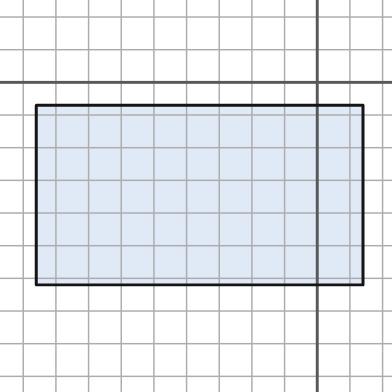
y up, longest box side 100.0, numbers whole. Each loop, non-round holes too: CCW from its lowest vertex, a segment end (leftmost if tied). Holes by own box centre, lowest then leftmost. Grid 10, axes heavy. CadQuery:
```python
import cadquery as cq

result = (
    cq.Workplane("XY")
    .moveTo(-86.0, -62.0)
    .lineTo(14.0, -62.0)
    .lineTo(14.0, -7.0)
    .lineTo(-86.0, -7.0)
    .close()
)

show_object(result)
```